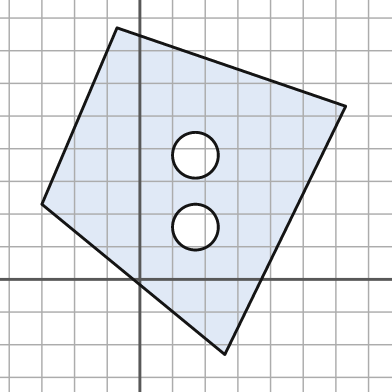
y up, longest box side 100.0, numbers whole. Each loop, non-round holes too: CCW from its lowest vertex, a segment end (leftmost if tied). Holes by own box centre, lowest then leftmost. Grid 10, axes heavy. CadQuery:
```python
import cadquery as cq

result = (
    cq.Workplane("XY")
    .moveTo(26.0, -23.0)
    .lineTo(63.0, 53.0)
    .lineTo(-7.0, 77.0)
    .lineTo(-30.0, 23.0)
    .close()
    .moveTo(17.0, 16.0)
    .circle(7.0)
    .moveTo(17.0, 38.0)
    .circle(7.0)
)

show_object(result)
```